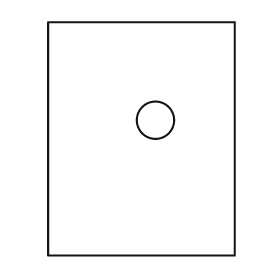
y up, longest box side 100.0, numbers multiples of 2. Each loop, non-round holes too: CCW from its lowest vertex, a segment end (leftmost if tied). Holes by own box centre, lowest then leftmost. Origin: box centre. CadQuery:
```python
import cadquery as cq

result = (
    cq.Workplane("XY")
    .moveTo(-40.0, -50.0)
    .lineTo(40.0, -50.0)
    .lineTo(40.0, 50.0)
    .lineTo(-40.0, 50.0)
    .close()
    .moveTo(6.0, 8.0)
    .circle(8.0)
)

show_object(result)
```